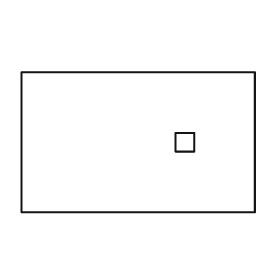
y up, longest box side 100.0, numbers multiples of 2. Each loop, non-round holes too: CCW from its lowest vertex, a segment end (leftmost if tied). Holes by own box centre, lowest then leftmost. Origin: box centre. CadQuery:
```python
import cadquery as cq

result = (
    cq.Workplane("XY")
    .moveTo(-50.0, -30.0)
    .lineTo(50.0, -30.0)
    .lineTo(50.0, 30.0)
    .lineTo(-50.0, 30.0)
    .close()
    .moveTo(16.0, -4.0)
    .lineTo(24.0, -4.0)
    .lineTo(24.0, 4.0)
    .lineTo(16.0, 4.0)
    .close()
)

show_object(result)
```